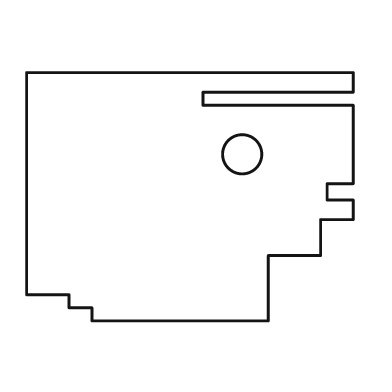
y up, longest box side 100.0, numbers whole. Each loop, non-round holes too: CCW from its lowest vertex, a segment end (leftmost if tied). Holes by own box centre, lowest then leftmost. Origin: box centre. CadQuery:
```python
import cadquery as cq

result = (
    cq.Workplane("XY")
    .moveTo(-30.0, -38.0)
    .lineTo(24.0, -38.0)
    .lineTo(24.0, -18.0)
    .lineTo(40.0, -18.0)
    .lineTo(40.0, -7.0)
    .lineTo(50.0, -7.0)
    .lineTo(50.0, -1.0)
    .lineTo(42.0, -1.0)
    .lineTo(42.0, 4.0)
    .lineTo(50.0, 4.0)
    .lineTo(50.0, 28.0)
    .lineTo(4.0, 28.0)
    .lineTo(4.0, 32.0)
    .lineTo(50.0, 32.0)
    .lineTo(50.0, 38.0)
    .lineTo(-50.0, 38.0)
    .lineTo(-50.0, -30.0)
    .lineTo(-37.0, -30.0)
    .lineTo(-37.0, -34.0)
    .lineTo(-30.0, -34.0)
    .close()
    .moveTo(16.0, 13.0)
    .circle(6.0)
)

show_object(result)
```